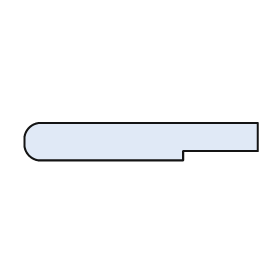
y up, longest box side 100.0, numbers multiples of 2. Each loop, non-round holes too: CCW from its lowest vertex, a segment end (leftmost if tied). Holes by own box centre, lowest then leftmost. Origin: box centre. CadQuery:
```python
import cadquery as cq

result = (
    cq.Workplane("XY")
    .moveTo(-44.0, -8.0)
    .lineTo(18.0, -8.0)
    .lineTo(18.0, -4.0)
    .lineTo(50.0, -4.0)
    .lineTo(50.0, 8.0)
    .lineTo(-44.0, 8.0)
    .threePointArc((-48.0, 6.0), (-50.0, 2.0))
    .lineTo(-50.0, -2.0)
    .threePointArc((-48.0, -6.0), (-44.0, -8.0))
    .close()
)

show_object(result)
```